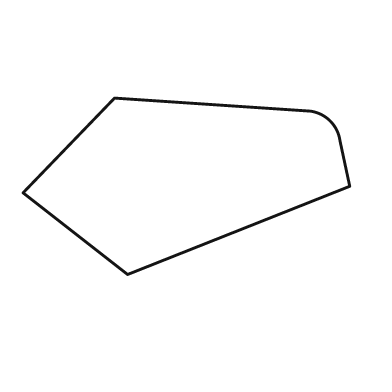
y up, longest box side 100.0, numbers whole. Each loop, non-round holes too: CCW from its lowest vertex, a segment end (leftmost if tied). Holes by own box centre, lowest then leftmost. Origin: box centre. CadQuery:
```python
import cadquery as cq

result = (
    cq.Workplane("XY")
    .moveTo(-18.0, -27.0)
    .lineTo(50.0, 0.0)
    .lineTo(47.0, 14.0)
    .threePointArc((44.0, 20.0), (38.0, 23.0))
    .lineTo(-22.0, 27.0)
    .lineTo(-50.0, -2.0)
    .close()
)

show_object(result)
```